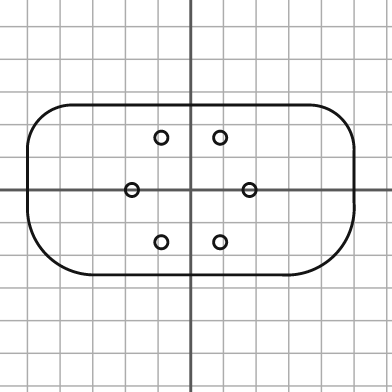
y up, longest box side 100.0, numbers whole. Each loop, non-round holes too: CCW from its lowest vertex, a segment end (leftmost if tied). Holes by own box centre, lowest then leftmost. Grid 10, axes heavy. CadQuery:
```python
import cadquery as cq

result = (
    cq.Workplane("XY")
    .moveTo(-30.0, -26.0)
    .lineTo(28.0, -26.0)
    .threePointArc((44.0, -20.0), (50.0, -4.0))
    .lineTo(50.0, 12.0)
    .threePointArc((46.0, 22.0), (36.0, 26.0))
    .lineTo(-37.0, 26.0)
    .threePointArc((-46.0, 22.0), (-50.0, 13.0))
    .lineTo(-50.0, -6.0)
    .threePointArc((-44.0, -20.0), (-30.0, -26.0))
    .close()
    .moveTo(-9.0, -16.0)
    .circle(2.0)
    .moveTo(9.0, -16.0)
    .circle(2.0)
    .moveTo(-18.0, 0.0)
    .circle(2.0)
    .moveTo(18.0, 0.0)
    .circle(2.0)
    .moveTo(-9.0, 16.0)
    .circle(2.0)
    .moveTo(9.0, 16.0)
    .circle(2.0)
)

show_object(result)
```